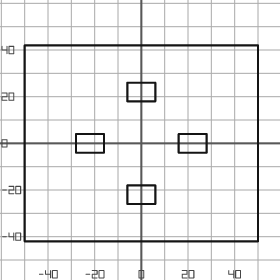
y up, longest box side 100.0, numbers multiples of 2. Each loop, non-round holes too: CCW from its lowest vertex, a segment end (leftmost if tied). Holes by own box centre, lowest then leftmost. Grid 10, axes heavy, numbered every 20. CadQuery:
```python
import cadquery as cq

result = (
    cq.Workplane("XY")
    .moveTo(-50.0, -42.0)
    .lineTo(50.0, -42.0)
    .lineTo(50.0, 42.0)
    .lineTo(-50.0, 42.0)
    .close()
    .moveTo(-6.0, -26.0)
    .lineTo(6.0, -26.0)
    .lineTo(6.0, -18.0)
    .lineTo(-6.0, -18.0)
    .close()
    .moveTo(-28.0, -4.0)
    .lineTo(-16.0, -4.0)
    .lineTo(-16.0, 4.0)
    .lineTo(-28.0, 4.0)
    .close()
    .moveTo(16.0, -4.0)
    .lineTo(28.0, -4.0)
    .lineTo(28.0, 4.0)
    .lineTo(16.0, 4.0)
    .close()
    .moveTo(-6.0, 18.0)
    .lineTo(6.0, 18.0)
    .lineTo(6.0, 26.0)
    .lineTo(-6.0, 26.0)
    .close()
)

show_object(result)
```